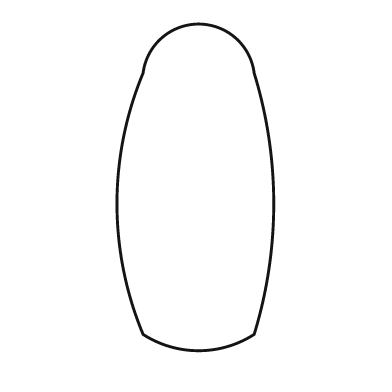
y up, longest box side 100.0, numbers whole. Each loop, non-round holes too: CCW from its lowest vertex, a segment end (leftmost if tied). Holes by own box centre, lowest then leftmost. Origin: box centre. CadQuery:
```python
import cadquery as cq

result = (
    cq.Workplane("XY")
    .moveTo(-16.0, -45.0)
    .threePointArc((1.0, -50.0), (18.0, -45.0))
    .threePointArc((24.0, -5.0), (18.0, 35.0))
    .threePointArc((1.0, 50.0), (-16.0, 35.0))
    .threePointArc((-24.0, -5.0), (-16.0, -45.0))
    .close()
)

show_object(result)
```